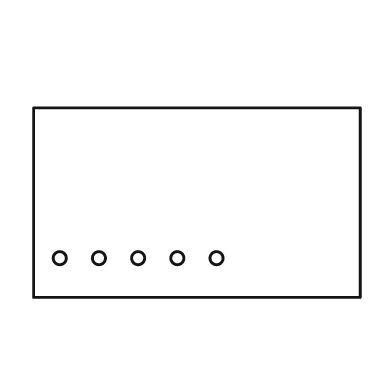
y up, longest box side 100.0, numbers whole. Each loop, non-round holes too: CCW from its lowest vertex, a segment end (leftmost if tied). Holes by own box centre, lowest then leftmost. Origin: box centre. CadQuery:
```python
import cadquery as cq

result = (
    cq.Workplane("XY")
    .moveTo(-50.0, -29.0)
    .lineTo(50.0, -29.0)
    .lineTo(50.0, 29.0)
    .lineTo(-50.0, 29.0)
    .close()
    .moveTo(-42.0, -17.0)
    .circle(2.0)
    .moveTo(-30.0, -17.0)
    .circle(2.0)
    .moveTo(-18.0, -17.0)
    .circle(2.0)
    .moveTo(-6.0, -17.0)
    .circle(2.0)
    .moveTo(6.0, -17.0)
    .circle(2.0)
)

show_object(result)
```